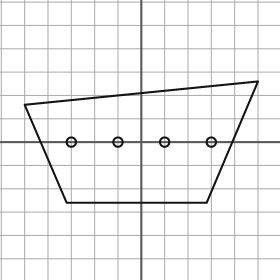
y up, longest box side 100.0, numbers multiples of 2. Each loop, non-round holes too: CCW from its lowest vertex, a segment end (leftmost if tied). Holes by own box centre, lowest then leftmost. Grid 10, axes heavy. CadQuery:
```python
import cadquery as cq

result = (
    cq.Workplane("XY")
    .moveTo(-32.0, -26.0)
    .lineTo(28.0, -26.0)
    .lineTo(50.0, 26.0)
    .lineTo(-50.0, 16.0)
    .close()
    .moveTo(-30.0, 0.0)
    .circle(2.0)
    .moveTo(-10.0, 0.0)
    .circle(2.0)
    .moveTo(10.0, 0.0)
    .circle(2.0)
    .moveTo(30.0, 0.0)
    .circle(2.0)
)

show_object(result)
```